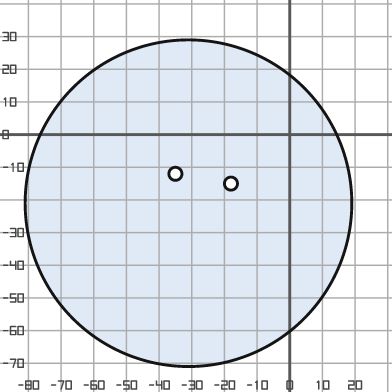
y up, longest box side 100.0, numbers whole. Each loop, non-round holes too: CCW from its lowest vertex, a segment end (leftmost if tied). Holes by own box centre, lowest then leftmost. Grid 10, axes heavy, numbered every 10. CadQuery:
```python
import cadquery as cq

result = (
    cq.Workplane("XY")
    .moveTo(-31.0, -21.0)
    .circle(50.0)
    .moveTo(-18.0, -15.0)
    .circle(2.0)
    .moveTo(-35.0, -12.0)
    .circle(2.0)
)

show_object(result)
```